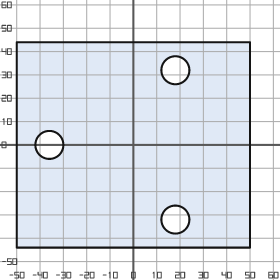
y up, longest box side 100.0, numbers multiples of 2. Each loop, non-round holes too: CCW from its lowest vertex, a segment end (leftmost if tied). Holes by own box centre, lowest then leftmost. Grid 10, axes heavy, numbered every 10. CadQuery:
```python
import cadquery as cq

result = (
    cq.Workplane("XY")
    .moveTo(-50.0, -44.0)
    .lineTo(50.0, -44.0)
    .lineTo(50.0, 44.0)
    .lineTo(-50.0, 44.0)
    .close()
    .moveTo(18.0, -32.0)
    .circle(6.0)
    .moveTo(-36.0, 0.0)
    .circle(6.0)
    .moveTo(18.0, 32.0)
    .circle(6.0)
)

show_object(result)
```